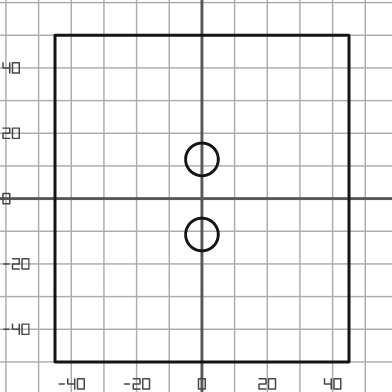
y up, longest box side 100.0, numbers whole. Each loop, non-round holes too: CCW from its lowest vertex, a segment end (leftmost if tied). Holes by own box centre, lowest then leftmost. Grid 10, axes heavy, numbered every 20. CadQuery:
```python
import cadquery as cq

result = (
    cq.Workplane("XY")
    .moveTo(-45.0, -50.0)
    .lineTo(45.0, -50.0)
    .lineTo(45.0, 50.0)
    .lineTo(-45.0, 50.0)
    .close()
    .moveTo(0.0, -11.0)
    .circle(5.0)
    .moveTo(0.0, 12.0)
    .circle(5.0)
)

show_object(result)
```